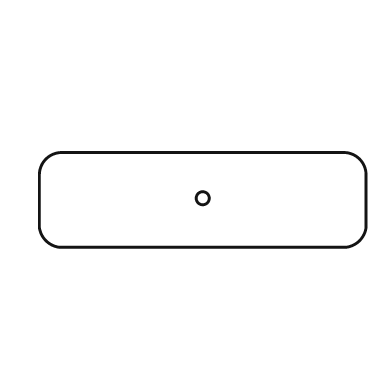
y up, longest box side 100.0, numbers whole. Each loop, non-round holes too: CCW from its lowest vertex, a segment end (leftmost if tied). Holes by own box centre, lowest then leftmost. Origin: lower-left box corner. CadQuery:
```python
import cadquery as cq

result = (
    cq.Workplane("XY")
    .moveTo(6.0, 0.0)
    .lineTo(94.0, 0.0)
    .threePointArc((98.0, 2.0), (100.0, 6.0))
    .lineTo(100.0, 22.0)
    .threePointArc((98.0, 27.0), (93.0, 29.0))
    .lineTo(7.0, 29.0)
    .threePointArc((2.0, 27.0), (0.0, 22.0))
    .lineTo(0.0, 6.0)
    .threePointArc((2.0, 2.0), (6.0, 0.0))
    .close()
    .moveTo(50.0, 15.0)
    .circle(2.0)
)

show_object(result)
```